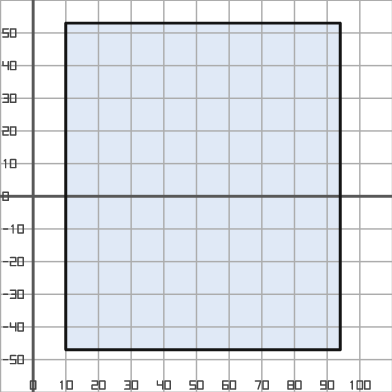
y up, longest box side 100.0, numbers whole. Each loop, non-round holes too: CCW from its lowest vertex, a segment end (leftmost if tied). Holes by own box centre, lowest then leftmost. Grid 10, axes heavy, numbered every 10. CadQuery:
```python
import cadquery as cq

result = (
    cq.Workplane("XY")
    .moveTo(10.0, -47.0)
    .lineTo(94.0, -47.0)
    .lineTo(94.0, 53.0)
    .lineTo(10.0, 53.0)
    .close()
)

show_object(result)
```